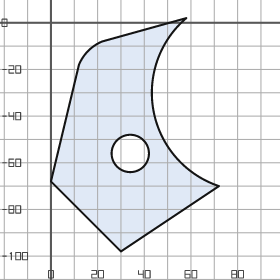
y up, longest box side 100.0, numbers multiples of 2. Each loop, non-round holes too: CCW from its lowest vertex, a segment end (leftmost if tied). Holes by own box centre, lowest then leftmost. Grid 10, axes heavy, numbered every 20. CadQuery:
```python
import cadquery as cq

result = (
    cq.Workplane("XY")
    .moveTo(30.0, -98.0)
    .lineTo(72.0, -70.0)
    .threePointArc((44.0, -38.0), (58.0, 2.0))
    .lineTo(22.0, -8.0)
    .threePointArc((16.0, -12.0), (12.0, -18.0))
    .lineTo(0.0, -68.0)
    .close()
    .moveTo(34.0, -56.0)
    .circle(8.0)
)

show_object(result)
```